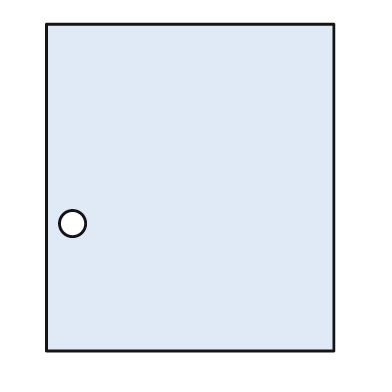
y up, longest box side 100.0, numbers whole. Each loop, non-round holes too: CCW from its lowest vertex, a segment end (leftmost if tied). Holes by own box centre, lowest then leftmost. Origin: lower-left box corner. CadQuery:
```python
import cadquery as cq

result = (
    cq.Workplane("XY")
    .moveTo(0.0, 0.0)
    .lineTo(88.0, 0.0)
    .lineTo(88.0, 100.0)
    .lineTo(0.0, 100.0)
    .close()
    .moveTo(8.0, 39.0)
    .circle(4.0)
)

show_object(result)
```